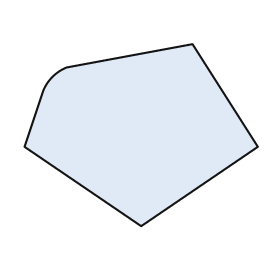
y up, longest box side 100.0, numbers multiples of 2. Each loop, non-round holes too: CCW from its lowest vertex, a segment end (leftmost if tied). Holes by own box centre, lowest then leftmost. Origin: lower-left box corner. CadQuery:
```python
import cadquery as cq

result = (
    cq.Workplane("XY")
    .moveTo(50.0, 0.0)
    .lineTo(100.0, 34.0)
    .lineTo(72.0, 78.0)
    .lineTo(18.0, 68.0)
    .threePointArc((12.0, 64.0), (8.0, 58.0))
    .lineTo(0.0, 34.0)
    .close()
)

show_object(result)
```